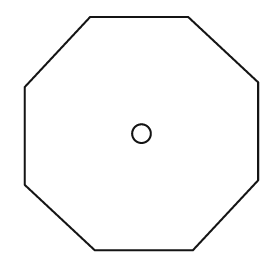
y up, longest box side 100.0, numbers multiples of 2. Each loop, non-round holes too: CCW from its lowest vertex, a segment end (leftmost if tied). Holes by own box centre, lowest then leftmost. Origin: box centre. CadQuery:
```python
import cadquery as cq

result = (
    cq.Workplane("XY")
    .moveTo(-20.0, -50.0)
    .lineTo(22.0, -50.0)
    .lineTo(50.0, -20.0)
    .lineTo(50.0, 22.0)
    .lineTo(20.0, 50.0)
    .lineTo(-22.0, 50.0)
    .lineTo(-50.0, 20.0)
    .lineTo(-50.0, -22.0)
    .close()
    .moveTo(0.0, 0.0)
    .circle(4.0)
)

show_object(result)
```